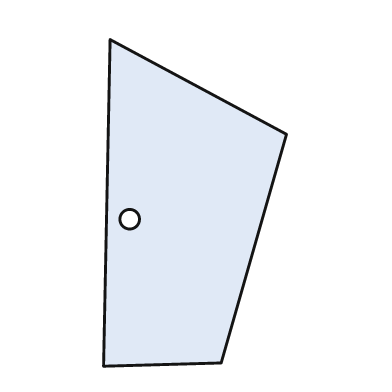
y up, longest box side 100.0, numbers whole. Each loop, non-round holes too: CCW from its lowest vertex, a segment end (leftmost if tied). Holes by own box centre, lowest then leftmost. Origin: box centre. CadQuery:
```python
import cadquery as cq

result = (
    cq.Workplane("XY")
    .moveTo(-28.0, -50.0)
    .lineTo(8.0, -49.0)
    .lineTo(28.0, 21.0)
    .lineTo(-26.0, 50.0)
    .close()
    .moveTo(-20.0, -5.0)
    .circle(3.0)
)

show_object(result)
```